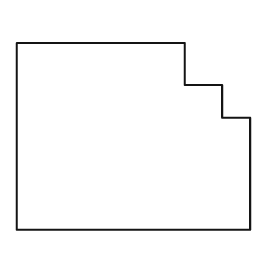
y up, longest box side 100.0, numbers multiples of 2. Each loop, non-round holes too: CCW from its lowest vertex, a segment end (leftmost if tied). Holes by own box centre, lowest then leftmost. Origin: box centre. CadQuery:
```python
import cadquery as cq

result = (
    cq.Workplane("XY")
    .moveTo(-50.0, -40.0)
    .lineTo(50.0, -40.0)
    .lineTo(50.0, 8.0)
    .lineTo(38.0, 8.0)
    .lineTo(38.0, 22.0)
    .lineTo(22.0, 22.0)
    .lineTo(22.0, 40.0)
    .lineTo(-50.0, 40.0)
    .close()
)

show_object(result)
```